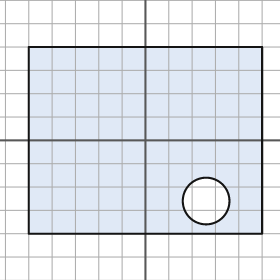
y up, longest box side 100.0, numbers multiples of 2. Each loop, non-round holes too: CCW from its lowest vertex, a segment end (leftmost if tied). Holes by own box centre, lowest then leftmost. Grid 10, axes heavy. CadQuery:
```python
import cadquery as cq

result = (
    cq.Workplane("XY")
    .moveTo(-50.0, -40.0)
    .lineTo(50.0, -40.0)
    .lineTo(50.0, 40.0)
    .lineTo(-50.0, 40.0)
    .close()
    .moveTo(26.0, -26.0)
    .circle(10.0)
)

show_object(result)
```